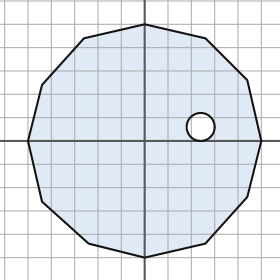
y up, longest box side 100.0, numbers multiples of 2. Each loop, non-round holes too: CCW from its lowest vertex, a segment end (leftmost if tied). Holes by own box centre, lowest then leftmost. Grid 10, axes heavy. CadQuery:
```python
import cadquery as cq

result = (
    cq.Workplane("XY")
    .moveTo(0.0, -50.0)
    .lineTo(26.0, -44.0)
    .lineTo(44.0, -24.0)
    .lineTo(50.0, 0.0)
    .lineTo(44.0, 26.0)
    .lineTo(26.0, 44.0)
    .lineTo(0.0, 50.0)
    .lineTo(-26.0, 44.0)
    .lineTo(-44.0, 24.0)
    .lineTo(-50.0, 0.0)
    .lineTo(-44.0, -26.0)
    .lineTo(-24.0, -44.0)
    .close()
    .moveTo(24.0, 6.0)
    .circle(6.0)
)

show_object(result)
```